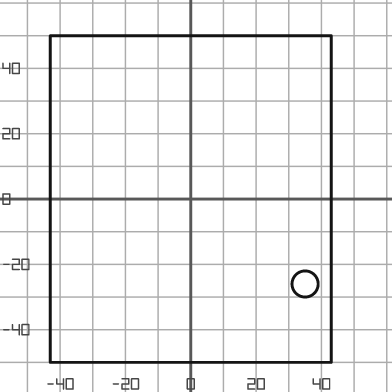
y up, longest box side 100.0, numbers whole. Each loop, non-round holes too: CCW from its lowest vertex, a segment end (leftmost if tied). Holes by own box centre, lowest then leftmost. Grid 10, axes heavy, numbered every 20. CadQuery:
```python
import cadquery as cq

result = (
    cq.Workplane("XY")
    .moveTo(-43.0, -50.0)
    .lineTo(43.0, -50.0)
    .lineTo(43.0, 50.0)
    .lineTo(-43.0, 50.0)
    .close()
    .moveTo(35.0, -26.0)
    .circle(4.0)
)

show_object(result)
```